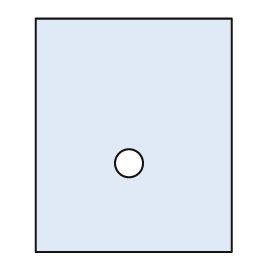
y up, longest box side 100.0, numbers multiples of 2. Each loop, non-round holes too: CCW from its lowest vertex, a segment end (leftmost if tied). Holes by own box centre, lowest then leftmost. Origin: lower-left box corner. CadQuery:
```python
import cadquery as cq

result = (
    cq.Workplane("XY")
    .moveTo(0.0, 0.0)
    .lineTo(84.0, 0.0)
    .lineTo(84.0, 100.0)
    .lineTo(0.0, 100.0)
    .close()
    .moveTo(40.0, 38.0)
    .circle(6.0)
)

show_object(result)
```